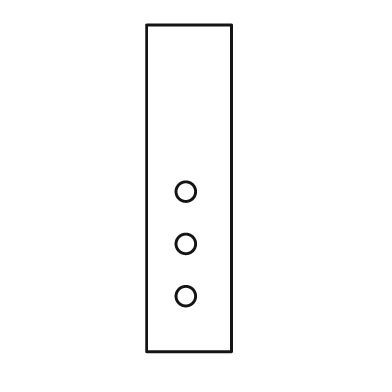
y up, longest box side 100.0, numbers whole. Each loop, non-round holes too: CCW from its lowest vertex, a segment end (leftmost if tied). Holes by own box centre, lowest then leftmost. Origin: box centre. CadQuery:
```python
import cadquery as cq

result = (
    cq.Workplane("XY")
    .moveTo(-13.0, -50.0)
    .lineTo(13.0, -50.0)
    .lineTo(13.0, 50.0)
    .lineTo(-13.0, 50.0)
    .close()
    .moveTo(-1.0, -33.0)
    .circle(3.0)
    .moveTo(-1.0, -17.0)
    .circle(3.0)
    .moveTo(-1.0, -1.0)
    .circle(3.0)
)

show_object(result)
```